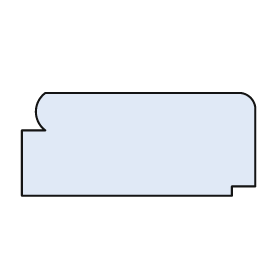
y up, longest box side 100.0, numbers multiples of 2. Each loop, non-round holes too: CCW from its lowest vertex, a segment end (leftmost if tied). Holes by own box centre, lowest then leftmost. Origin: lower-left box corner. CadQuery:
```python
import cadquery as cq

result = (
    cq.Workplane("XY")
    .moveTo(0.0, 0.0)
    .lineTo(90.0, 0.0)
    .lineTo(90.0, 4.0)
    .lineTo(100.0, 4.0)
    .lineTo(100.0, 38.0)
    .threePointArc((98.0, 42.0), (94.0, 44.0))
    .lineTo(10.0, 44.0)
    .threePointArc((6.0, 36.0), (10.0, 28.0))
    .lineTo(0.0, 28.0)
    .close()
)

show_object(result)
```